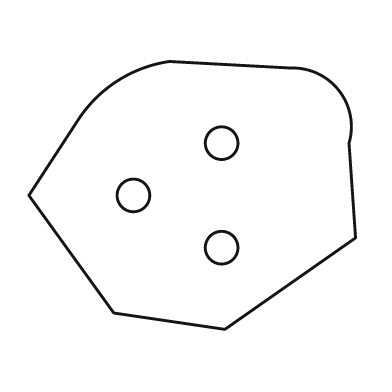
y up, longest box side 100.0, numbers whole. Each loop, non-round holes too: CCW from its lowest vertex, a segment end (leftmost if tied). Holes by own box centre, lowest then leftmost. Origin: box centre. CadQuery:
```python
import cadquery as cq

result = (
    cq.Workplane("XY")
    .moveTo(10.0, -41.0)
    .lineTo(50.0, -13.0)
    .lineTo(48.0, 16.0)
    .threePointArc((45.0, 32.0), (30.0, 39.0))
    .lineTo(-7.0, 41.0)
    .threePointArc((-23.0, 35.0), (-35.0, 23.0))
    .lineTo(-50.0, 0.0)
    .lineTo(-24.0, -36.0)
    .close()
    .moveTo(9.0, -16.0)
    .circle(5.0)
    .moveTo(-18.0, 0.0)
    .circle(5.0)
    .moveTo(9.0, 16.0)
    .circle(5.0)
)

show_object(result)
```